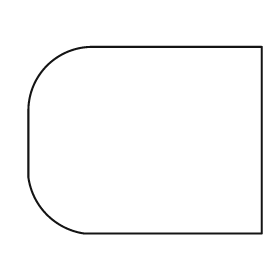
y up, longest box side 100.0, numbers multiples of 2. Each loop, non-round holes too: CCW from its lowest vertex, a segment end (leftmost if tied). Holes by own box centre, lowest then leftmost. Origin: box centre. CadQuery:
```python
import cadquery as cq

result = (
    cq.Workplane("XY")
    .moveTo(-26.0, -40.0)
    .lineTo(50.0, -40.0)
    .lineTo(50.0, 40.0)
    .lineTo(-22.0, 40.0)
    .threePointArc((-42.0, 32.0), (-50.0, 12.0))
    .lineTo(-50.0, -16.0)
    .threePointArc((-42.0, -32.0), (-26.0, -40.0))
    .close()
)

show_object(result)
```